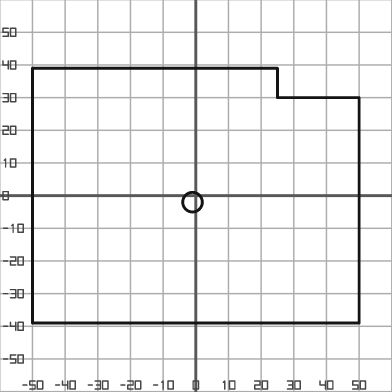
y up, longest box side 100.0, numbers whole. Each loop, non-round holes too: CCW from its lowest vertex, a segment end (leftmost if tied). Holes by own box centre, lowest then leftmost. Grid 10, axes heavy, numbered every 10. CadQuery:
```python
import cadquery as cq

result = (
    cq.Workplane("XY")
    .moveTo(-50.0, -39.0)
    .lineTo(50.0, -39.0)
    .lineTo(50.0, 30.0)
    .lineTo(25.0, 30.0)
    .lineTo(25.0, 39.0)
    .lineTo(-50.0, 39.0)
    .close()
    .moveTo(-1.0, -2.0)
    .circle(3.0)
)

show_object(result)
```